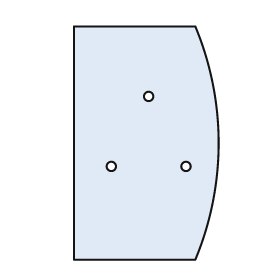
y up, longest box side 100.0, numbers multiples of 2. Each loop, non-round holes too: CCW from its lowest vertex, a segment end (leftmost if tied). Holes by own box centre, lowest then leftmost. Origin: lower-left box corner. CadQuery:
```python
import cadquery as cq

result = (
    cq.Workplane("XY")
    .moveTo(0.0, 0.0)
    .lineTo(52.0, 0.0)
    .threePointArc((62.0, 50.0), (52.0, 100.0))
    .lineTo(0.0, 100.0)
    .close()
    .moveTo(16.0, 40.0)
    .circle(2.0)
    .moveTo(48.0, 40.0)
    .circle(2.0)
    .moveTo(32.0, 70.0)
    .circle(2.0)
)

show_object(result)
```